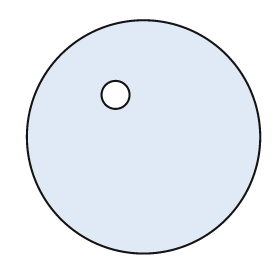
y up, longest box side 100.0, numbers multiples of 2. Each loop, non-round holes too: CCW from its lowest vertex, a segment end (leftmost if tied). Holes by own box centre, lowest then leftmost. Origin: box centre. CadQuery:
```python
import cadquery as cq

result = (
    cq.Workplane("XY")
    .moveTo(0.0, 0.0)
    .circle(50.0)
    .moveTo(-12.0, 18.0)
    .circle(6.0)
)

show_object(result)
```